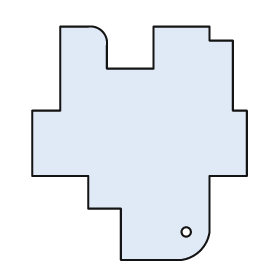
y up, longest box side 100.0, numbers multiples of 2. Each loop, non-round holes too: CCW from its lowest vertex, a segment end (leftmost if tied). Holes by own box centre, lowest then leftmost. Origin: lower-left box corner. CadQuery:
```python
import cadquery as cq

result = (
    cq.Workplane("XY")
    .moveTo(38.0, 0.0)
    .lineTo(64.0, 0.0)
    .threePointArc((72.0, 4.0), (76.0, 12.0))
    .lineTo(76.0, 36.0)
    .lineTo(92.0, 36.0)
    .lineTo(92.0, 64.0)
    .lineTo(86.0, 64.0)
    .lineTo(86.0, 94.0)
    .lineTo(76.0, 94.0)
    .lineTo(76.0, 100.0)
    .lineTo(52.0, 100.0)
    .lineTo(52.0, 82.0)
    .lineTo(32.0, 82.0)
    .lineTo(32.0, 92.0)
    .threePointArc((30.0, 98.0), (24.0, 100.0))
    .lineTo(12.0, 100.0)
    .lineTo(12.0, 64.0)
    .lineTo(0.0, 64.0)
    .lineTo(0.0, 36.0)
    .lineTo(24.0, 36.0)
    .lineTo(24.0, 22.0)
    .lineTo(38.0, 22.0)
    .close()
    .moveTo(66.0, 12.0)
    .circle(2.0)
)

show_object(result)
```